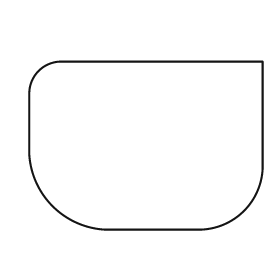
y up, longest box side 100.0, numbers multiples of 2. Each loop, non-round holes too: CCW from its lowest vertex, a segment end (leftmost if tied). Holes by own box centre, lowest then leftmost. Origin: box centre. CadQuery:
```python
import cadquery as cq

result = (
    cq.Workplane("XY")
    .moveTo(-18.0, -36.0)
    .lineTo(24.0, -36.0)
    .threePointArc((42.0, -28.0), (50.0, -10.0))
    .lineTo(50.0, 36.0)
    .lineTo(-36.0, 36.0)
    .threePointArc((-46.0, 32.0), (-50.0, 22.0))
    .lineTo(-50.0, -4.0)
    .threePointArc((-40.0, -26.0), (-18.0, -36.0))
    .close()
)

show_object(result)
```